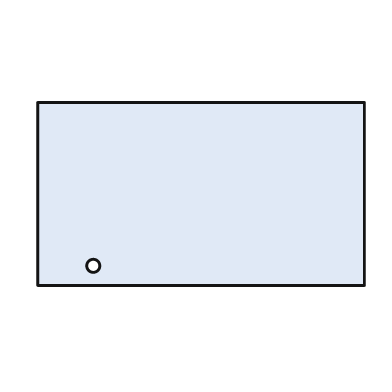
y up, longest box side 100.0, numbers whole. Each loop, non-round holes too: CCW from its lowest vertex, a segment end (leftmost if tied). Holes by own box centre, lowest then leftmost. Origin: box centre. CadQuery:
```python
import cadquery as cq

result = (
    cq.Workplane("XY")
    .moveTo(-50.0, -28.0)
    .lineTo(50.0, -28.0)
    .lineTo(50.0, 28.0)
    .lineTo(-50.0, 28.0)
    .close()
    .moveTo(-33.0, -22.0)
    .circle(2.0)
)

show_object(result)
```